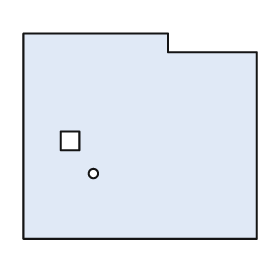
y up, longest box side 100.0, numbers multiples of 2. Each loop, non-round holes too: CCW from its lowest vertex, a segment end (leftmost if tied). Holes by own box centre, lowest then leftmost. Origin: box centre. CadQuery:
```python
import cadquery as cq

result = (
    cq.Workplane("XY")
    .moveTo(-50.0, -44.0)
    .lineTo(50.0, -44.0)
    .lineTo(50.0, 36.0)
    .lineTo(12.0, 36.0)
    .lineTo(12.0, 44.0)
    .lineTo(-50.0, 44.0)
    .close()
    .moveTo(-20.0, -16.0)
    .circle(2.0)
    .moveTo(-34.0, -6.0)
    .lineTo(-26.0, -6.0)
    .lineTo(-26.0, 2.0)
    .lineTo(-34.0, 2.0)
    .close()
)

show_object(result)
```